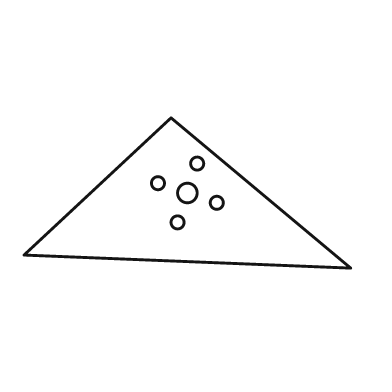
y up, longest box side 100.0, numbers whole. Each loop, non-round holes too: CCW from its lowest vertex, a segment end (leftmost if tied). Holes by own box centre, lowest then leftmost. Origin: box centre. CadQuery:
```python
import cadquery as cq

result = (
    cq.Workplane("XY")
    .moveTo(50.0, -23.0)
    .lineTo(-5.0, 23.0)
    .lineTo(-50.0, -19.0)
    .close()
    .moveTo(-3.0, -9.0)
    .circle(2.0)
    .moveTo(9.0, -3.0)
    .circle(2.0)
    .moveTo(0.0, 0.0)
    .circle(3.0)
    .moveTo(-9.0, 3.0)
    .circle(2.0)
    .moveTo(3.0, 9.0)
    .circle(2.0)
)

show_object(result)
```